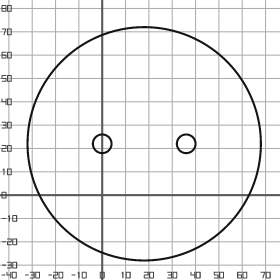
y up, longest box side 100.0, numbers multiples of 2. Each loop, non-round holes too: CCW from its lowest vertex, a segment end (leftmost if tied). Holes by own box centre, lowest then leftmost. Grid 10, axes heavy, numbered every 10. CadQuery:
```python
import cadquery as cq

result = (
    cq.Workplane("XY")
    .moveTo(18.0, 22.0)
    .circle(50.0)
    .moveTo(0.0, 22.0)
    .circle(4.0)
    .moveTo(36.0, 22.0)
    .circle(4.0)
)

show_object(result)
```